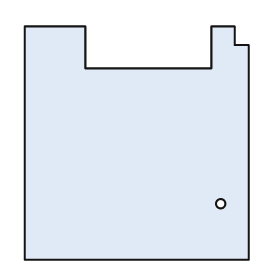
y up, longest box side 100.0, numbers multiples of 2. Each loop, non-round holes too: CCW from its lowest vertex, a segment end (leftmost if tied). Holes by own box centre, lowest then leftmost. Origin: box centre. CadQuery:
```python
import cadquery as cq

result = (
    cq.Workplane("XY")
    .moveTo(-48.0, -50.0)
    .lineTo(48.0, -50.0)
    .lineTo(48.0, 42.0)
    .lineTo(42.0, 42.0)
    .lineTo(42.0, 50.0)
    .lineTo(32.0, 50.0)
    .lineTo(32.0, 32.0)
    .lineTo(-22.0, 32.0)
    .lineTo(-22.0, 50.0)
    .lineTo(-48.0, 50.0)
    .close()
    .moveTo(36.0, -26.0)
    .circle(2.0)
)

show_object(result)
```